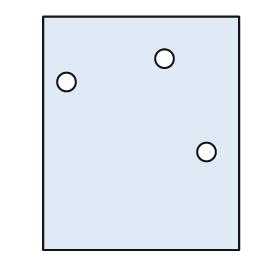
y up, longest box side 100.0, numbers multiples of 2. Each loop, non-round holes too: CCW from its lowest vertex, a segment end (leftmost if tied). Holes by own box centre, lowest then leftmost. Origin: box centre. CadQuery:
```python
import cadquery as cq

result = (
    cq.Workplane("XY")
    .moveTo(-42.0, -50.0)
    .lineTo(42.0, -50.0)
    .lineTo(42.0, 50.0)
    .lineTo(-42.0, 50.0)
    .close()
    .moveTo(28.0, -8.0)
    .circle(4.0)
    .moveTo(-32.0, 22.0)
    .circle(4.0)
    .moveTo(10.0, 32.0)
    .circle(4.0)
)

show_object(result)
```